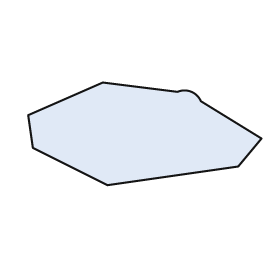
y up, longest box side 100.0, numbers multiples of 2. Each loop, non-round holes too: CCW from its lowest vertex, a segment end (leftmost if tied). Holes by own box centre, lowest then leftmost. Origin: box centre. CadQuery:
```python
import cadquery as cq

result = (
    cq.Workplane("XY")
    .moveTo(-16.0, -22.0)
    .lineTo(40.0, -14.0)
    .lineTo(50.0, -2.0)
    .lineTo(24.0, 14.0)
    .threePointArc((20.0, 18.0), (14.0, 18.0))
    .lineTo(-18.0, 22.0)
    .lineTo(-50.0, 8.0)
    .lineTo(-48.0, -6.0)
    .close()
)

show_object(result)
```